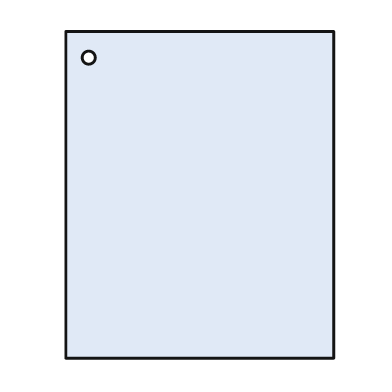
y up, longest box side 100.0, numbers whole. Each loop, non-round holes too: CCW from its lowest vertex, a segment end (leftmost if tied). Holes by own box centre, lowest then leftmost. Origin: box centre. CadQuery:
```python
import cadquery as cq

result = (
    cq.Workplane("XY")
    .moveTo(-41.0, -50.0)
    .lineTo(41.0, -50.0)
    .lineTo(41.0, 50.0)
    .lineTo(-41.0, 50.0)
    .close()
    .moveTo(-34.0, 42.0)
    .circle(2.0)
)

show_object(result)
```